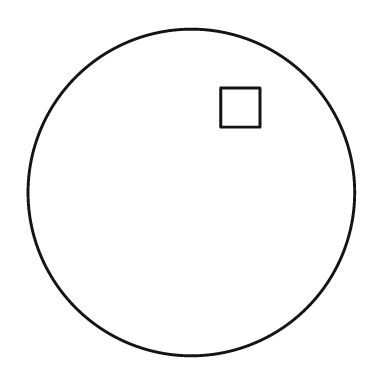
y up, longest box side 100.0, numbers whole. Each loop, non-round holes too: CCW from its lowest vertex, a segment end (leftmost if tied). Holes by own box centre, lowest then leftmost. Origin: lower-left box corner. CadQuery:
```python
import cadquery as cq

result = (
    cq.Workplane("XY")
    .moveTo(50.0, 50.0)
    .circle(50.0)
    .moveTo(59.0, 70.0)
    .lineTo(71.0, 70.0)
    .lineTo(71.0, 82.0)
    .lineTo(59.0, 82.0)
    .close()
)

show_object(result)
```